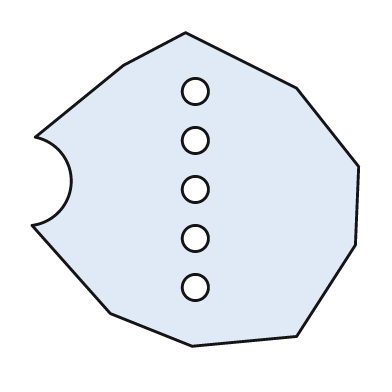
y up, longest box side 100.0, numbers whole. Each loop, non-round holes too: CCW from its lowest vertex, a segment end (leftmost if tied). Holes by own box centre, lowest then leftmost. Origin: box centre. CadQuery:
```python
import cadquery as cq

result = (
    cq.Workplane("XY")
    .moveTo(-1.0, -48.0)
    .lineTo(31.0, -45.0)
    .lineTo(49.0, -17.0)
    .lineTo(50.0, 7.0)
    .lineTo(31.0, 31.0)
    .lineTo(-3.0, 48.0)
    .lineTo(-22.0, 38.0)
    .lineTo(-49.0, 16.0)
    .threePointArc((-38.0, 2.0), (-50.0, -11.0))
    .lineTo(-26.0, -38.0)
    .close()
    .moveTo(0.0, -30.0)
    .circle(4.0)
    .moveTo(0.0, -15.0)
    .circle(4.0)
    .moveTo(0.0, 0.0)
    .circle(4.0)
    .moveTo(0.0, 15.0)
    .circle(4.0)
    .moveTo(0.0, 30.0)
    .circle(4.0)
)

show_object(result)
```